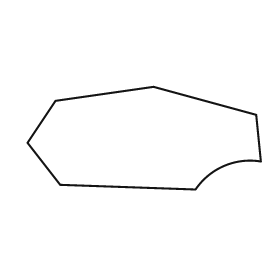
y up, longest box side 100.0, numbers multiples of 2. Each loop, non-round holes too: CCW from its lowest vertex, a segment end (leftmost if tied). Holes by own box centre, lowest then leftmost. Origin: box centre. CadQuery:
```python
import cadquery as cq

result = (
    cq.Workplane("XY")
    .moveTo(22.0, -22.0)
    .threePointArc((34.0, -12.0), (50.0, -10.0))
    .lineTo(48.0, 10.0)
    .lineTo(4.0, 22.0)
    .lineTo(-38.0, 16.0)
    .lineTo(-50.0, -2.0)
    .lineTo(-36.0, -20.0)
    .close()
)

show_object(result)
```